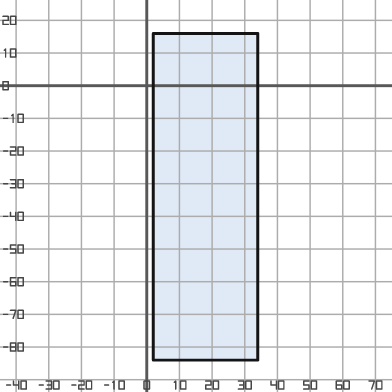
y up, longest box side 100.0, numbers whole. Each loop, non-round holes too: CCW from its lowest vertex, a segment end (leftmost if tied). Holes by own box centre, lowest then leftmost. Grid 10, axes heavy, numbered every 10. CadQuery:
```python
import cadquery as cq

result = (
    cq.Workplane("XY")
    .moveTo(2.0, -84.0)
    .lineTo(34.0, -84.0)
    .lineTo(34.0, 16.0)
    .lineTo(2.0, 16.0)
    .close()
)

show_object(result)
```